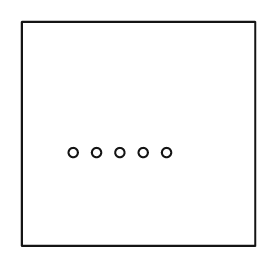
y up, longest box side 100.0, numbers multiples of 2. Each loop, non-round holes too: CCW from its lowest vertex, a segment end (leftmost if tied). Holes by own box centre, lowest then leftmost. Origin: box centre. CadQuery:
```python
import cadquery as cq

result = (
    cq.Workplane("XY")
    .moveTo(-50.0, -48.0)
    .lineTo(50.0, -48.0)
    .lineTo(50.0, 48.0)
    .lineTo(-50.0, 48.0)
    .close()
    .moveTo(-28.0, -8.0)
    .circle(2.0)
    .moveTo(-18.0, -8.0)
    .circle(2.0)
    .moveTo(-8.0, -8.0)
    .circle(2.0)
    .moveTo(2.0, -8.0)
    .circle(2.0)
    .moveTo(12.0, -8.0)
    .circle(2.0)
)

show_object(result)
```